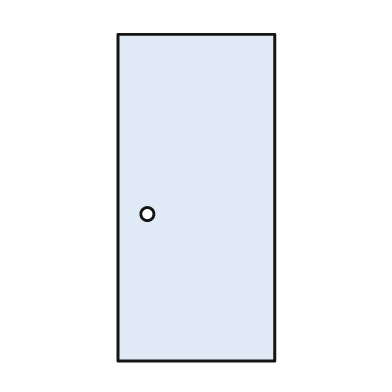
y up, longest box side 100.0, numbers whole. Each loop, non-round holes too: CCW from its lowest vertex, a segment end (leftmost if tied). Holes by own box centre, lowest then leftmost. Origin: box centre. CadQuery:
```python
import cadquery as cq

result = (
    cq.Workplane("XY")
    .moveTo(-24.0, -50.0)
    .lineTo(24.0, -50.0)
    .lineTo(24.0, 50.0)
    .lineTo(-24.0, 50.0)
    .close()
    .moveTo(-15.0, -5.0)
    .circle(2.0)
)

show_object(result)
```